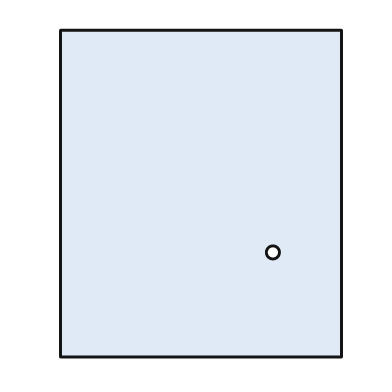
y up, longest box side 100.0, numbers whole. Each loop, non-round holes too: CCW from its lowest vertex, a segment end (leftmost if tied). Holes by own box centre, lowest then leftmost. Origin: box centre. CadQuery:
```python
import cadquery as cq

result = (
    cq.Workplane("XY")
    .moveTo(-43.0, -50.0)
    .lineTo(43.0, -50.0)
    .lineTo(43.0, 50.0)
    .lineTo(-43.0, 50.0)
    .close()
    .moveTo(22.0, -18.0)
    .circle(2.0)
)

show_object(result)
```